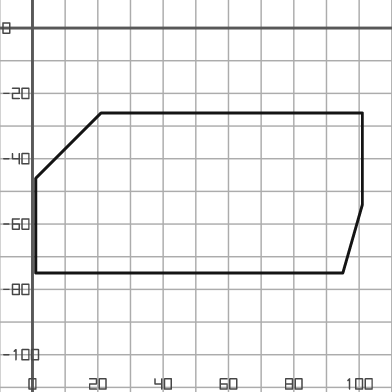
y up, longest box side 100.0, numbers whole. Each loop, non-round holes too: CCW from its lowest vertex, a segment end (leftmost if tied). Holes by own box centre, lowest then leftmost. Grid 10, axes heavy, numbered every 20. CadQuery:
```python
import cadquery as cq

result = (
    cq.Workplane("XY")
    .moveTo(1.0, -75.0)
    .lineTo(95.0, -75.0)
    .lineTo(101.0, -54.0)
    .lineTo(101.0, -26.0)
    .lineTo(21.0, -26.0)
    .lineTo(1.0, -46.0)
    .close()
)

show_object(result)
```